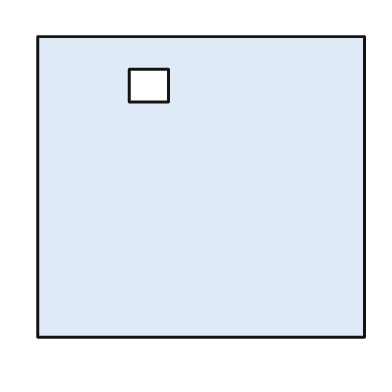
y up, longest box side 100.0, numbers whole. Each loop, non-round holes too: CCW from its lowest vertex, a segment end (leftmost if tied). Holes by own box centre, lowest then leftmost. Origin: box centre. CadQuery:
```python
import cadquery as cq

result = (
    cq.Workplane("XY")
    .moveTo(-50.0, -46.0)
    .lineTo(50.0, -46.0)
    .lineTo(50.0, 46.0)
    .lineTo(-50.0, 46.0)
    .close()
    .moveTo(-22.0, 26.0)
    .lineTo(-10.0, 26.0)
    .lineTo(-10.0, 36.0)
    .lineTo(-22.0, 36.0)
    .close()
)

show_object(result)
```